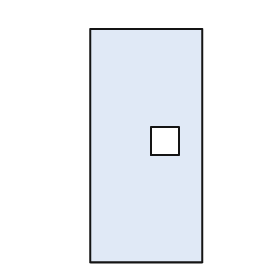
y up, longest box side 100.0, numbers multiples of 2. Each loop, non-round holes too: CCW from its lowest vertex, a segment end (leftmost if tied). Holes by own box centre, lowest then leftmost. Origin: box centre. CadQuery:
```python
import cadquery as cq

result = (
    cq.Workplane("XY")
    .moveTo(-24.0, -50.0)
    .lineTo(24.0, -50.0)
    .lineTo(24.0, 50.0)
    .lineTo(-24.0, 50.0)
    .close()
    .moveTo(2.0, -4.0)
    .lineTo(14.0, -4.0)
    .lineTo(14.0, 8.0)
    .lineTo(2.0, 8.0)
    .close()
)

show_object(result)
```